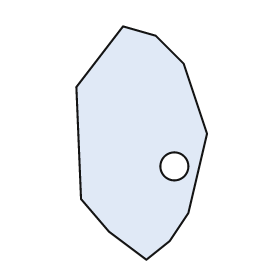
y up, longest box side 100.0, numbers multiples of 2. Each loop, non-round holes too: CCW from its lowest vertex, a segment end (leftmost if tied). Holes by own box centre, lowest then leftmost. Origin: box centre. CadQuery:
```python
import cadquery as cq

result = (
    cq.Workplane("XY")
    .moveTo(2.0, -50.0)
    .lineTo(12.0, -42.0)
    .lineTo(20.0, -30.0)
    .lineTo(28.0, 4.0)
    .lineTo(18.0, 34.0)
    .lineTo(6.0, 46.0)
    .lineTo(-8.0, 50.0)
    .lineTo(-28.0, 24.0)
    .lineTo(-26.0, -24.0)
    .lineTo(-14.0, -38.0)
    .close()
    .moveTo(14.0, -10.0)
    .circle(6.0)
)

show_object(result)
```